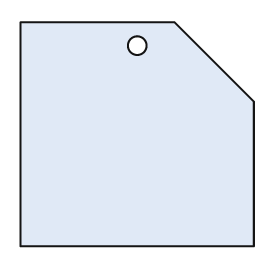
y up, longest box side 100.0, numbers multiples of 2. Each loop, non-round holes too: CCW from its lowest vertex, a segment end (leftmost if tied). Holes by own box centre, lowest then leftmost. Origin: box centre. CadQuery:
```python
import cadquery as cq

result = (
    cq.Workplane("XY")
    .moveTo(-50.0, -48.0)
    .lineTo(50.0, -48.0)
    .lineTo(50.0, 14.0)
    .lineTo(16.0, 48.0)
    .lineTo(-50.0, 48.0)
    .close()
    .moveTo(0.0, 38.0)
    .circle(4.0)
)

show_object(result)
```